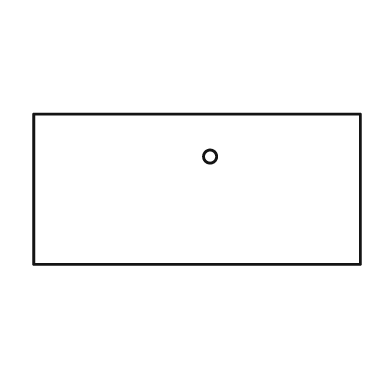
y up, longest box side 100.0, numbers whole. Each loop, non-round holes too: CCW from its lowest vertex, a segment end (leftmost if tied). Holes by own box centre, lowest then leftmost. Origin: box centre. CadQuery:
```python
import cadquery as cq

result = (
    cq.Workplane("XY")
    .moveTo(-50.0, -23.0)
    .lineTo(50.0, -23.0)
    .lineTo(50.0, 23.0)
    .lineTo(-50.0, 23.0)
    .close()
    .moveTo(4.0, 10.0)
    .circle(2.0)
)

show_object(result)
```